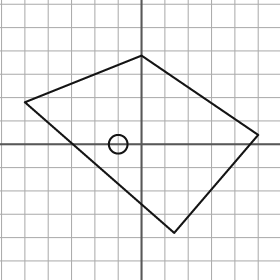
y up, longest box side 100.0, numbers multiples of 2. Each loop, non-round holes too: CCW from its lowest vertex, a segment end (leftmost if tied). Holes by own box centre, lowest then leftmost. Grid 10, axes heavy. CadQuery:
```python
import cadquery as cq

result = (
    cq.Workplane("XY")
    .moveTo(14.0, -38.0)
    .lineTo(50.0, 4.0)
    .lineTo(0.0, 38.0)
    .lineTo(-50.0, 18.0)
    .close()
    .moveTo(-10.0, 0.0)
    .circle(4.0)
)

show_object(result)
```